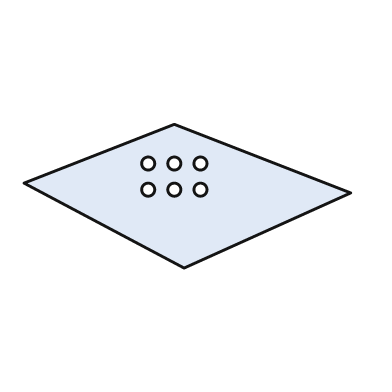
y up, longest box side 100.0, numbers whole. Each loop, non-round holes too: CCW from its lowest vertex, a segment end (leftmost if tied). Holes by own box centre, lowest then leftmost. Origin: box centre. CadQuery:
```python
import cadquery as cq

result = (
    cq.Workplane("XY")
    .moveTo(-1.0, -22.0)
    .lineTo(50.0, 1.0)
    .lineTo(-4.0, 22.0)
    .lineTo(-50.0, 4.0)
    .close()
    .moveTo(-12.0, 2.0)
    .circle(2.0)
    .moveTo(-4.0, 2.0)
    .circle(2.0)
    .moveTo(4.0, 2.0)
    .circle(2.0)
    .moveTo(-12.0, 10.0)
    .circle(2.0)
    .moveTo(-4.0, 10.0)
    .circle(2.0)
    .moveTo(4.0, 10.0)
    .circle(2.0)
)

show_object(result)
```